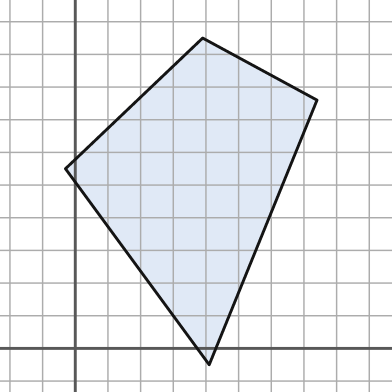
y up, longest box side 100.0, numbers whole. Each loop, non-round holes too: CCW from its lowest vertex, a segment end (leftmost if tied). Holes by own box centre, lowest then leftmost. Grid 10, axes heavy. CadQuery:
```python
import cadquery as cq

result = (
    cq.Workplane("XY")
    .moveTo(41.0, -5.0)
    .lineTo(74.0, 76.0)
    .lineTo(39.0, 95.0)
    .lineTo(-3.0, 55.0)
    .close()
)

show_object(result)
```